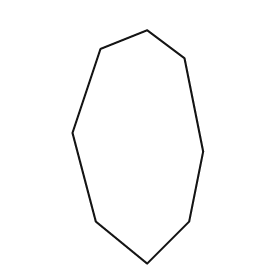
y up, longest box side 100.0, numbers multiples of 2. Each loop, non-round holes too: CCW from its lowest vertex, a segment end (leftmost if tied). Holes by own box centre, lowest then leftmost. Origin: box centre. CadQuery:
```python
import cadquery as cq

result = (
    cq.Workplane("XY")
    .moveTo(4.0, -50.0)
    .lineTo(22.0, -32.0)
    .lineTo(28.0, -2.0)
    .lineTo(20.0, 38.0)
    .lineTo(4.0, 50.0)
    .lineTo(-16.0, 42.0)
    .lineTo(-28.0, 6.0)
    .lineTo(-18.0, -32.0)
    .close()
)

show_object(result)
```